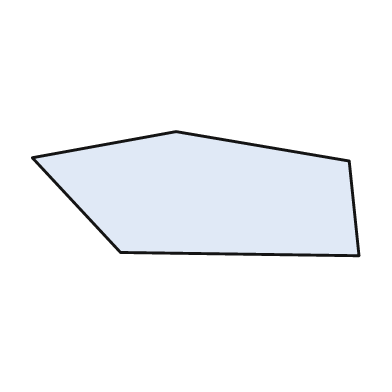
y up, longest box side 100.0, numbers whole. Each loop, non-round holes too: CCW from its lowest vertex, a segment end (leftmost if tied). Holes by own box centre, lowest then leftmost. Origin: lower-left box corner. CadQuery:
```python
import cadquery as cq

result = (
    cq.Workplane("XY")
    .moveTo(100.0, 0.0)
    .lineTo(97.0, 29.0)
    .lineTo(44.0, 38.0)
    .lineTo(0.0, 30.0)
    .lineTo(27.0, 1.0)
    .close()
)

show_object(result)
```